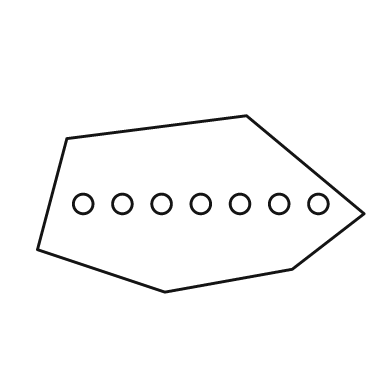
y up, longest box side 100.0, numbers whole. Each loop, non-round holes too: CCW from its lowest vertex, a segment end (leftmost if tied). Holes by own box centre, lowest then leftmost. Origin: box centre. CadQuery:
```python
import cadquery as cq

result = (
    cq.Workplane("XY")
    .moveTo(-11.0, -27.0)
    .lineTo(28.0, -20.0)
    .lineTo(50.0, -3.0)
    .lineTo(14.0, 27.0)
    .lineTo(-41.0, 20.0)
    .lineTo(-50.0, -14.0)
    .close()
    .moveTo(-36.0, 0.0)
    .circle(3.0)
    .moveTo(-24.0, 0.0)
    .circle(3.0)
    .moveTo(-12.0, 0.0)
    .circle(3.0)
    .moveTo(0.0, 0.0)
    .circle(3.0)
    .moveTo(12.0, 0.0)
    .circle(3.0)
    .moveTo(24.0, 0.0)
    .circle(3.0)
    .moveTo(36.0, 0.0)
    .circle(3.0)
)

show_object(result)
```